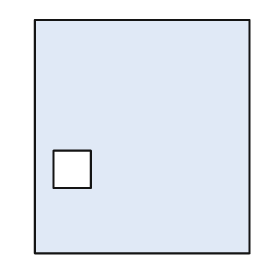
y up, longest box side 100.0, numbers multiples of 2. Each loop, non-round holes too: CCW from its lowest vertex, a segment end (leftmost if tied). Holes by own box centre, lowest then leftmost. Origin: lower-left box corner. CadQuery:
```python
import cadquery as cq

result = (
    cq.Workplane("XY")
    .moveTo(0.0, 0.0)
    .lineTo(92.0, 0.0)
    .lineTo(92.0, 100.0)
    .lineTo(0.0, 100.0)
    .close()
    .moveTo(8.0, 28.0)
    .lineTo(24.0, 28.0)
    .lineTo(24.0, 44.0)
    .lineTo(8.0, 44.0)
    .close()
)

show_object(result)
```